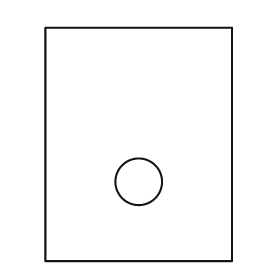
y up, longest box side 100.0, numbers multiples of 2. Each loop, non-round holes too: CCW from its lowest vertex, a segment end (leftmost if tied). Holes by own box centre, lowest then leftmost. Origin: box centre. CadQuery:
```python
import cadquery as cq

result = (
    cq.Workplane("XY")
    .moveTo(-40.0, -50.0)
    .lineTo(40.0, -50.0)
    .lineTo(40.0, 50.0)
    .lineTo(-40.0, 50.0)
    .close()
    .moveTo(0.0, -16.0)
    .circle(10.0)
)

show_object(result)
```